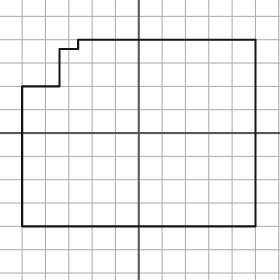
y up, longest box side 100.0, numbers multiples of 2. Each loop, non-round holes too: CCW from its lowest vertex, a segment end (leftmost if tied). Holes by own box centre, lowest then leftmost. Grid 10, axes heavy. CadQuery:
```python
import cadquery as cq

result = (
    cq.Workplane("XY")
    .moveTo(-50.0, -40.0)
    .lineTo(50.0, -40.0)
    .lineTo(50.0, 40.0)
    .lineTo(-26.0, 40.0)
    .lineTo(-26.0, 36.0)
    .lineTo(-34.0, 36.0)
    .lineTo(-34.0, 20.0)
    .lineTo(-50.0, 20.0)
    .close()
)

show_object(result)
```